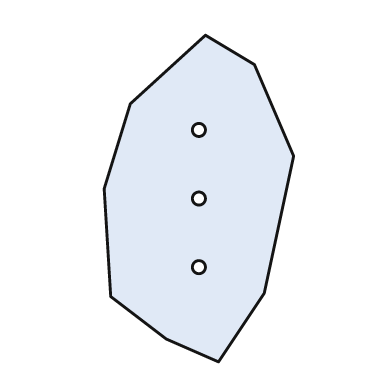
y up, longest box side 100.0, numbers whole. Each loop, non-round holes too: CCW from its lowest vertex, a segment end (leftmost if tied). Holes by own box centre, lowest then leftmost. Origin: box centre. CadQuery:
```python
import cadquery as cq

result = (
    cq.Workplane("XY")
    .moveTo(6.0, -50.0)
    .lineTo(20.0, -29.0)
    .lineTo(29.0, 13.0)
    .lineTo(17.0, 41.0)
    .lineTo(2.0, 50.0)
    .lineTo(-21.0, 29.0)
    .lineTo(-29.0, 3.0)
    .lineTo(-27.0, -30.0)
    .lineTo(-10.0, -43.0)
    .close()
    .moveTo(0.0, -21.0)
    .circle(2.0)
    .moveTo(0.0, 0.0)
    .circle(2.0)
    .moveTo(0.0, 21.0)
    .circle(2.0)
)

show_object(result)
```